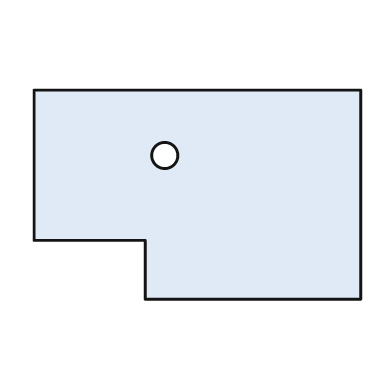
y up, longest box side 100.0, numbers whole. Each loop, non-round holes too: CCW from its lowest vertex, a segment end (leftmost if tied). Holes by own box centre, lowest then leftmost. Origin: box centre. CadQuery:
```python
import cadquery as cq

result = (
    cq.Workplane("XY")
    .moveTo(-16.0, -32.0)
    .lineTo(50.0, -32.0)
    .lineTo(50.0, 32.0)
    .lineTo(-50.0, 32.0)
    .lineTo(-50.0, -14.0)
    .lineTo(-16.0, -14.0)
    .close()
    .moveTo(-10.0, 12.0)
    .circle(4.0)
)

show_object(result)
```